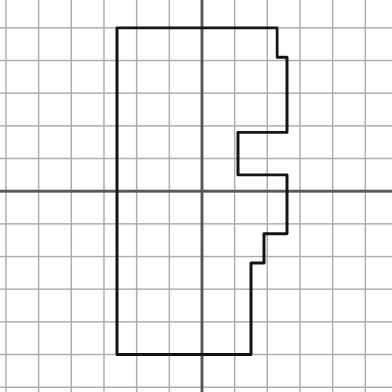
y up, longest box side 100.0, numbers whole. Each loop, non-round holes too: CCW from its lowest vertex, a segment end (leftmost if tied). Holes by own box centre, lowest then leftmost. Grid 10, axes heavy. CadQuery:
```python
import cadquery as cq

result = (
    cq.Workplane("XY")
    .moveTo(-26.0, -50.0)
    .lineTo(15.0, -50.0)
    .lineTo(15.0, -22.0)
    .lineTo(19.0, -22.0)
    .lineTo(19.0, -13.0)
    .lineTo(26.0, -13.0)
    .lineTo(26.0, 5.0)
    .lineTo(11.0, 5.0)
    .lineTo(11.0, 18.0)
    .lineTo(26.0, 18.0)
    .lineTo(26.0, 41.0)
    .lineTo(23.0, 41.0)
    .lineTo(23.0, 50.0)
    .lineTo(-26.0, 50.0)
    .close()
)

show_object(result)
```